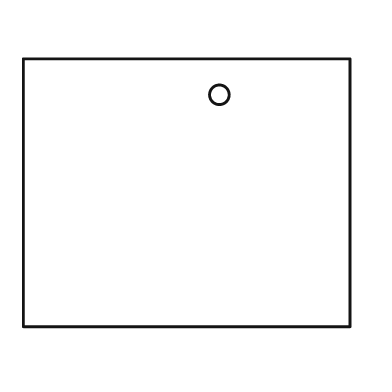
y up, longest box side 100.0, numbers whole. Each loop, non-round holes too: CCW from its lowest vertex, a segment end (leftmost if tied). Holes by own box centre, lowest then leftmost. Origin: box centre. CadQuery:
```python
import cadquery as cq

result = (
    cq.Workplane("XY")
    .moveTo(-50.0, -41.0)
    .lineTo(50.0, -41.0)
    .lineTo(50.0, 41.0)
    .lineTo(-50.0, 41.0)
    .close()
    .moveTo(10.0, 30.0)
    .circle(3.0)
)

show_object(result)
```